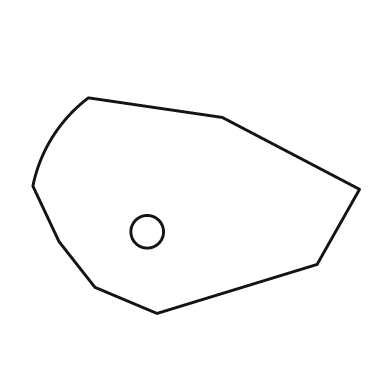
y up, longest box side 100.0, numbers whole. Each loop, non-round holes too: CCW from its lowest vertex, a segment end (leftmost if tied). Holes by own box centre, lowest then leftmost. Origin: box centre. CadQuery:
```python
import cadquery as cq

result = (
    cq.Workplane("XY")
    .moveTo(-12.0, -33.0)
    .lineTo(37.0, -18.0)
    .lineTo(50.0, 5.0)
    .lineTo(8.0, 27.0)
    .lineTo(-33.0, 33.0)
    .threePointArc((-44.0, 21.0), (-50.0, 6.0))
    .lineTo(-42.0, -11.0)
    .lineTo(-31.0, -25.0)
    .close()
    .moveTo(-15.0, -8.0)
    .circle(5.0)
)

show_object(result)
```